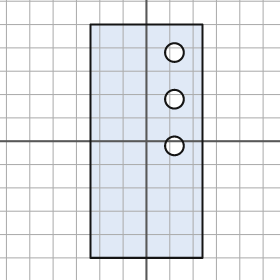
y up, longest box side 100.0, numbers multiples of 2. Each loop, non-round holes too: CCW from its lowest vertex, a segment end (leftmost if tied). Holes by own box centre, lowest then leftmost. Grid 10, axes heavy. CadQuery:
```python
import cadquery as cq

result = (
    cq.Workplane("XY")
    .moveTo(-24.0, -50.0)
    .lineTo(24.0, -50.0)
    .lineTo(24.0, 50.0)
    .lineTo(-24.0, 50.0)
    .close()
    .moveTo(12.0, -2.0)
    .circle(4.0)
    .moveTo(12.0, 18.0)
    .circle(4.0)
    .moveTo(12.0, 38.0)
    .circle(4.0)
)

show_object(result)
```